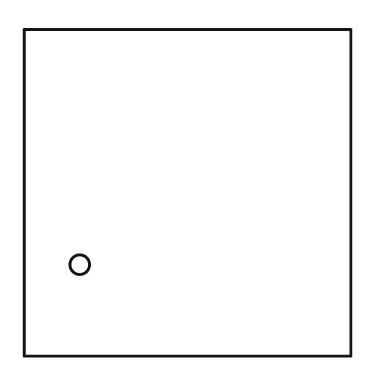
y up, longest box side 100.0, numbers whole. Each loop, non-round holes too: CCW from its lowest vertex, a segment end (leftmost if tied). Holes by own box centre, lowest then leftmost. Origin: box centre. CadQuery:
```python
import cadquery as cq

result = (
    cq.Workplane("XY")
    .moveTo(-50.0, -50.0)
    .lineTo(50.0, -50.0)
    .lineTo(50.0, 50.0)
    .lineTo(-50.0, 50.0)
    .close()
    .moveTo(-33.0, -22.0)
    .circle(3.0)
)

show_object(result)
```